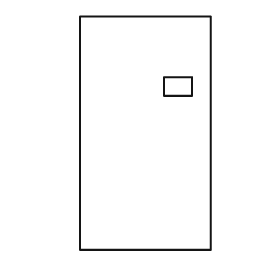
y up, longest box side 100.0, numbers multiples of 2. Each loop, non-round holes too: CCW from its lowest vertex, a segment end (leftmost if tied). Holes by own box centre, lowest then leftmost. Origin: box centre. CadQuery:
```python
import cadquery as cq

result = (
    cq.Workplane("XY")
    .moveTo(-28.0, -50.0)
    .lineTo(28.0, -50.0)
    .lineTo(28.0, 50.0)
    .lineTo(-28.0, 50.0)
    .close()
    .moveTo(8.0, 16.0)
    .lineTo(20.0, 16.0)
    .lineTo(20.0, 24.0)
    .lineTo(8.0, 24.0)
    .close()
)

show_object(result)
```